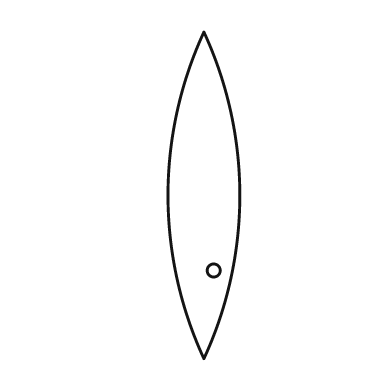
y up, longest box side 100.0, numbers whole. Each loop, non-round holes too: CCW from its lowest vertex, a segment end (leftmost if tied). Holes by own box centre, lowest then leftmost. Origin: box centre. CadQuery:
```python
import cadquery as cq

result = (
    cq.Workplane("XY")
    .moveTo(0.0, -50.0)
    .threePointArc((11.0, 0.0), (0.0, 50.0))
    .threePointArc((-11.0, 0.0), (0.0, -50.0))
    .close()
    .moveTo(3.0, -23.0)
    .circle(2.0)
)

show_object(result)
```